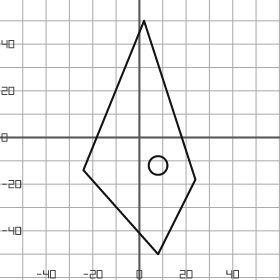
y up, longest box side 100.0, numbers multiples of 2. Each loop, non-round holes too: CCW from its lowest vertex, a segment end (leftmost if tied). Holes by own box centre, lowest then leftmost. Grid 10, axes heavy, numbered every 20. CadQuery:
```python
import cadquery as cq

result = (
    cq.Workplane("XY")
    .moveTo(8.0, -50.0)
    .lineTo(24.0, -18.0)
    .lineTo(2.0, 50.0)
    .lineTo(-24.0, -14.0)
    .close()
    .moveTo(8.0, -12.0)
    .circle(4.0)
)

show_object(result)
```